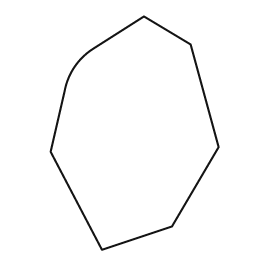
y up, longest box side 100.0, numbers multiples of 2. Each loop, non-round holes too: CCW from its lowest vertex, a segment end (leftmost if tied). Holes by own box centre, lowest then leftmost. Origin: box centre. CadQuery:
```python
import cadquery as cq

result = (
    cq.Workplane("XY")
    .moveTo(-14.0, -50.0)
    .lineTo(16.0, -40.0)
    .lineTo(36.0, -6.0)
    .lineTo(24.0, 38.0)
    .lineTo(4.0, 50.0)
    .lineTo(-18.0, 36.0)
    .threePointArc((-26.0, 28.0), (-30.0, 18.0))
    .lineTo(-36.0, -8.0)
    .close()
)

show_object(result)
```